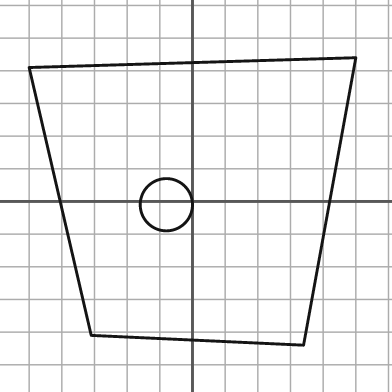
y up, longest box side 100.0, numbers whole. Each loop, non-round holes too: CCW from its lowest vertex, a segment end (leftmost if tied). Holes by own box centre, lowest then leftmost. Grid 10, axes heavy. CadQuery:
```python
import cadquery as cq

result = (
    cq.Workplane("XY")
    .moveTo(34.0, -44.0)
    .lineTo(50.0, 44.0)
    .lineTo(-50.0, 41.0)
    .lineTo(-31.0, -41.0)
    .close()
    .moveTo(-8.0, -1.0)
    .circle(8.0)
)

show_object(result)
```